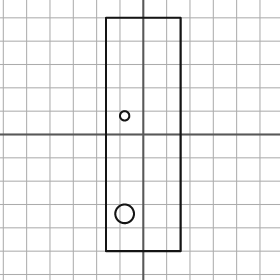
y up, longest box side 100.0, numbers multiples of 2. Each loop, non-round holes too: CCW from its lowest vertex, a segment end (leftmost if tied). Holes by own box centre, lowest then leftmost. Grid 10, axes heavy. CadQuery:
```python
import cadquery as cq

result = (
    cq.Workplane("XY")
    .moveTo(-16.0, -50.0)
    .lineTo(16.0, -50.0)
    .lineTo(16.0, 50.0)
    .lineTo(-16.0, 50.0)
    .close()
    .moveTo(-8.0, -34.0)
    .circle(4.0)
    .moveTo(-8.0, 8.0)
    .circle(2.0)
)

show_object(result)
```